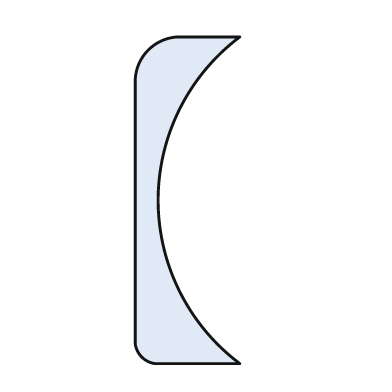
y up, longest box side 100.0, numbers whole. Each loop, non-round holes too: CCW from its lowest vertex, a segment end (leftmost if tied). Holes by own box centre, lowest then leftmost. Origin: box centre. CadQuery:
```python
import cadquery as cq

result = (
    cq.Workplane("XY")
    .moveTo(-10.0, -50.0)
    .lineTo(16.0, -50.0)
    .threePointArc((-9.0, 0.0), (16.0, 50.0))
    .lineTo(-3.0, 50.0)
    .threePointArc((-12.0, 46.0), (-16.0, 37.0))
    .lineTo(-16.0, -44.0)
    .threePointArc((-14.0, -48.0), (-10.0, -50.0))
    .close()
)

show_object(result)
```